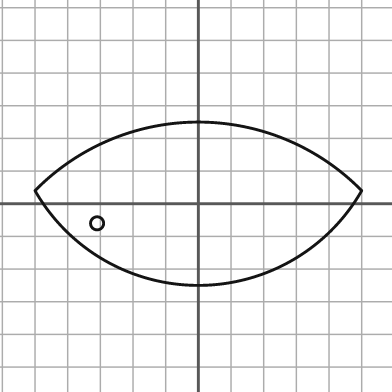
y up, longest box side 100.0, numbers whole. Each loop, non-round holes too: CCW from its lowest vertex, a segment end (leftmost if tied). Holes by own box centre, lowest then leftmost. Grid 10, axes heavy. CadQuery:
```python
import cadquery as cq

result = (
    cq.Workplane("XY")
    .moveTo(-50.0, 4.0)
    .threePointArc((0.0, -25.0), (50.0, 4.0))
    .threePointArc((0.0, 25.0), (-50.0, 4.0))
    .close()
    .moveTo(-31.0, -6.0)
    .circle(2.0)
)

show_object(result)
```